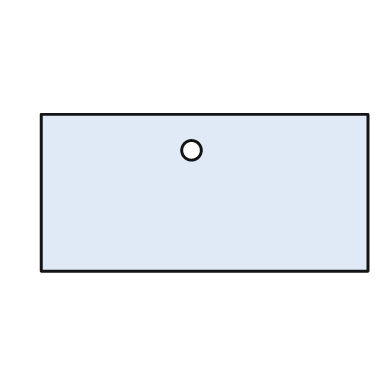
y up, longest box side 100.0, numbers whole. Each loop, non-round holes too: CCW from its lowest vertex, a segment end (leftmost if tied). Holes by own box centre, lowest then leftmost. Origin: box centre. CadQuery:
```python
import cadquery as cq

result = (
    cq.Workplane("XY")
    .moveTo(-50.0, -24.0)
    .lineTo(50.0, -24.0)
    .lineTo(50.0, 24.0)
    .lineTo(-50.0, 24.0)
    .close()
    .moveTo(-4.0, 13.0)
    .circle(3.0)
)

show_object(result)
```